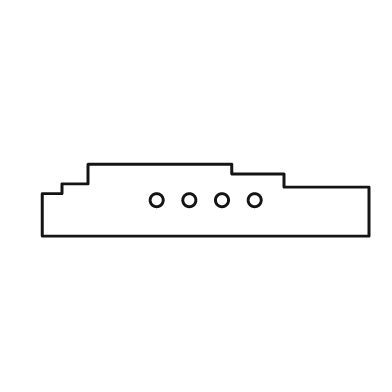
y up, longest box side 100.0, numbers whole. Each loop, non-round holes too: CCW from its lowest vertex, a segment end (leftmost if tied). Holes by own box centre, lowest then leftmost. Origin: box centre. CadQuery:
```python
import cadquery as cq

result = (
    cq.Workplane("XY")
    .moveTo(-50.0, -11.0)
    .lineTo(50.0, -11.0)
    .lineTo(50.0, 4.0)
    .lineTo(24.0, 4.0)
    .lineTo(24.0, 8.0)
    .lineTo(8.0, 8.0)
    .lineTo(8.0, 11.0)
    .lineTo(-36.0, 11.0)
    .lineTo(-36.0, 5.0)
    .lineTo(-44.0, 5.0)
    .lineTo(-44.0, 2.0)
    .lineTo(-50.0, 2.0)
    .close()
    .moveTo(-15.0, 0.0)
    .circle(2.0)
    .moveTo(-5.0, 0.0)
    .circle(2.0)
    .moveTo(5.0, 0.0)
    .circle(2.0)
    .moveTo(15.0, 0.0)
    .circle(2.0)
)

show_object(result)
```